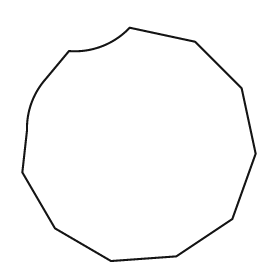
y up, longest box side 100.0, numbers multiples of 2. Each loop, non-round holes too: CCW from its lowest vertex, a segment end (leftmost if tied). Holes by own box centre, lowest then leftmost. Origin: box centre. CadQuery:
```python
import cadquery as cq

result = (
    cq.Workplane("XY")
    .moveTo(-12.0, -50.0)
    .lineTo(16.0, -48.0)
    .lineTo(40.0, -32.0)
    .lineTo(50.0, -4.0)
    .lineTo(44.0, 24.0)
    .lineTo(24.0, 44.0)
    .lineTo(-4.0, 50.0)
    .threePointArc((-16.0, 42.0), (-30.0, 40.0))
    .lineTo(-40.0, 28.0)
    .threePointArc((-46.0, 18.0), (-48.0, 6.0))
    .lineTo(-50.0, -12.0)
    .lineTo(-36.0, -36.0)
    .close()
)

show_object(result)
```